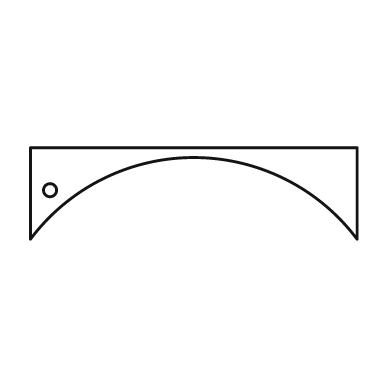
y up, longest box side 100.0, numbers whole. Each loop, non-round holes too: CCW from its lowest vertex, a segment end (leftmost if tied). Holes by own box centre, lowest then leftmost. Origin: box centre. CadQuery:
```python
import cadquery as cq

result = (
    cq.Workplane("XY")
    .moveTo(-50.0, -14.0)
    .threePointArc((0.0, 11.0), (50.0, -14.0))
    .lineTo(50.0, 14.0)
    .lineTo(-50.0, 14.0)
    .close()
    .moveTo(-44.0, 1.0)
    .circle(2.0)
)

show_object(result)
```